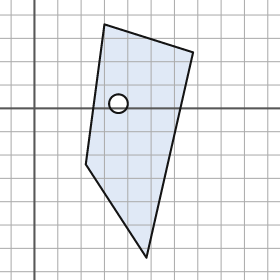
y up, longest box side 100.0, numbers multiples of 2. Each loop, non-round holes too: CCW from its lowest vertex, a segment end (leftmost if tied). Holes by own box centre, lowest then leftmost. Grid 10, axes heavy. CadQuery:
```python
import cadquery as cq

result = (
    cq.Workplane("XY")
    .moveTo(48.0, -64.0)
    .lineTo(68.0, 24.0)
    .lineTo(30.0, 36.0)
    .lineTo(22.0, -24.0)
    .close()
    .moveTo(36.0, 2.0)
    .circle(4.0)
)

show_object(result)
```